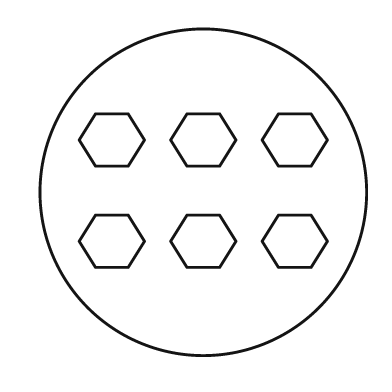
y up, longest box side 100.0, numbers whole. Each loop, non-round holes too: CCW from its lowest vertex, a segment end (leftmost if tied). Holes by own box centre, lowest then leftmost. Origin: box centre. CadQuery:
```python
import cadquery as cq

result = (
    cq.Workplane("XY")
    .moveTo(0.0, 0.0)
    .circle(50.0)
    .moveTo(-33.0, -23.0)
    .lineTo(-23.0, -23.0)
    .lineTo(-18.0, -15.0)
    .lineTo(-23.0, -7.0)
    .lineTo(-33.0, -7.0)
    .lineTo(-38.0, -15.0)
    .close()
    .moveTo(-5.0, -23.0)
    .lineTo(5.0, -23.0)
    .lineTo(10.0, -15.0)
    .lineTo(5.0, -7.0)
    .lineTo(-5.0, -7.0)
    .lineTo(-10.0, -15.0)
    .close()
    .moveTo(23.0, -23.0)
    .lineTo(33.0, -23.0)
    .lineTo(38.0, -15.0)
    .lineTo(33.0, -7.0)
    .lineTo(23.0, -7.0)
    .lineTo(18.0, -15.0)
    .close()
    .moveTo(-33.0, 8.0)
    .lineTo(-23.0, 8.0)
    .lineTo(-18.0, 16.0)
    .lineTo(-23.0, 24.0)
    .lineTo(-33.0, 24.0)
    .lineTo(-38.0, 16.0)
    .close()
    .moveTo(-5.0, 8.0)
    .lineTo(5.0, 8.0)
    .lineTo(10.0, 16.0)
    .lineTo(5.0, 24.0)
    .lineTo(-5.0, 24.0)
    .lineTo(-10.0, 16.0)
    .close()
    .moveTo(23.0, 8.0)
    .lineTo(33.0, 8.0)
    .lineTo(38.0, 16.0)
    .lineTo(33.0, 24.0)
    .lineTo(23.0, 24.0)
    .lineTo(18.0, 16.0)
    .close()
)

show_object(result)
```